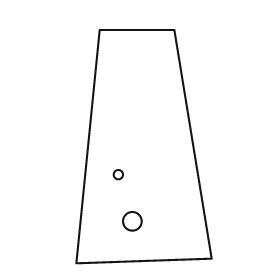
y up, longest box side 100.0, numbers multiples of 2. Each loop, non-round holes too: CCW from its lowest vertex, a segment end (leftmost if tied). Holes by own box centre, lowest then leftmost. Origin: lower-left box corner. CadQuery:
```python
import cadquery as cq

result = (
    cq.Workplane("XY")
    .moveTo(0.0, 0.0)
    .lineTo(58.0, 2.0)
    .lineTo(42.0, 100.0)
    .lineTo(10.0, 100.0)
    .close()
    .moveTo(24.0, 18.0)
    .circle(4.0)
    .moveTo(18.0, 38.0)
    .circle(2.0)
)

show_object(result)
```